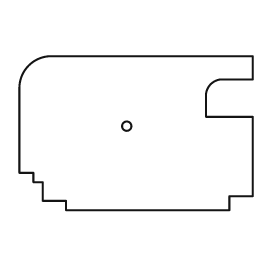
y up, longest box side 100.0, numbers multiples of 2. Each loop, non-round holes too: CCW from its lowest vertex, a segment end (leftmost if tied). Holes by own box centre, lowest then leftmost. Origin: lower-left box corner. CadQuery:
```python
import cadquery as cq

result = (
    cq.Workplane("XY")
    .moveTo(20.0, 0.0)
    .lineTo(90.0, 0.0)
    .lineTo(90.0, 6.0)
    .lineTo(100.0, 6.0)
    .lineTo(100.0, 40.0)
    .lineTo(80.0, 40.0)
    .lineTo(80.0, 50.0)
    .threePointArc((82.0, 54.0), (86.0, 56.0))
    .lineTo(100.0, 56.0)
    .lineTo(100.0, 66.0)
    .lineTo(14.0, 66.0)
    .threePointArc((4.0, 62.0), (0.0, 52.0))
    .lineTo(0.0, 16.0)
    .lineTo(6.0, 16.0)
    .lineTo(6.0, 12.0)
    .lineTo(10.0, 12.0)
    .lineTo(10.0, 4.0)
    .lineTo(20.0, 4.0)
    .close()
    .moveTo(46.0, 36.0)
    .circle(2.0)
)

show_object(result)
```